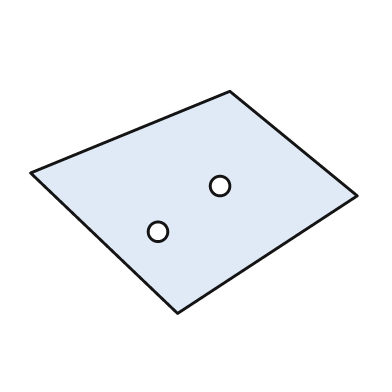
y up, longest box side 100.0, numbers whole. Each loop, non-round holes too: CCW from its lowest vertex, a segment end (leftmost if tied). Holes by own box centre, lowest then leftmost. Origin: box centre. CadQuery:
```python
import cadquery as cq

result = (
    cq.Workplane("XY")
    .moveTo(-5.0, -34.0)
    .lineTo(50.0, 2.0)
    .lineTo(11.0, 34.0)
    .lineTo(-50.0, 9.0)
    .close()
    .moveTo(-11.0, -9.0)
    .circle(3.0)
    .moveTo(8.0, 5.0)
    .circle(3.0)
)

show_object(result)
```